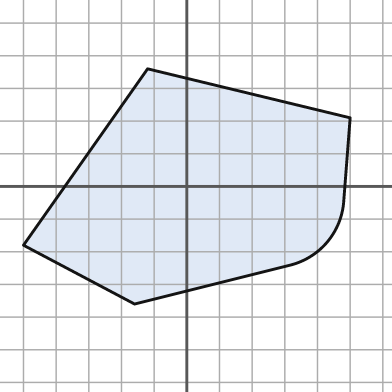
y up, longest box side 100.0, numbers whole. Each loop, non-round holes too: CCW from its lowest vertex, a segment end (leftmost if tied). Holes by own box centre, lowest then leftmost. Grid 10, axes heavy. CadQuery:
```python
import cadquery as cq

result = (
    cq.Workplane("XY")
    .moveTo(-16.0, -36.0)
    .lineTo(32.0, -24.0)
    .threePointArc((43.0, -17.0), (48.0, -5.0))
    .lineTo(50.0, 21.0)
    .lineTo(-12.0, 36.0)
    .lineTo(-50.0, -18.0)
    .close()
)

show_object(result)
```